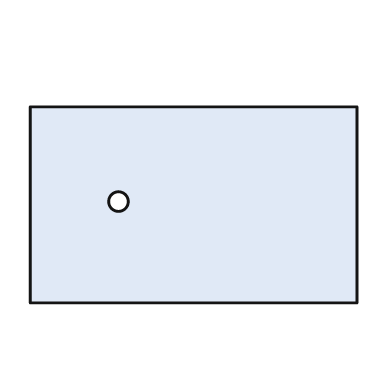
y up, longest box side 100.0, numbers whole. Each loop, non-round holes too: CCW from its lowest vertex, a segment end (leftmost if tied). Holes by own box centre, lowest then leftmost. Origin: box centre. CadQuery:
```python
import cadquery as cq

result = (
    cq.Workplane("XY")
    .moveTo(-50.0, -30.0)
    .lineTo(50.0, -30.0)
    .lineTo(50.0, 30.0)
    .lineTo(-50.0, 30.0)
    .close()
    .moveTo(-23.0, 1.0)
    .circle(3.0)
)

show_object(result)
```